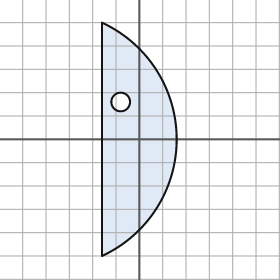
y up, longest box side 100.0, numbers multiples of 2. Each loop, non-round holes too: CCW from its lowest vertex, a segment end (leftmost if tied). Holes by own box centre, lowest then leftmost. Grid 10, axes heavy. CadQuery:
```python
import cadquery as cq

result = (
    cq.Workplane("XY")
    .moveTo(-16.0, -50.0)
    .threePointArc((16.0, 0.0), (-16.0, 50.0))
    .close()
    .moveTo(-8.0, 16.0)
    .circle(4.0)
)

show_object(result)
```